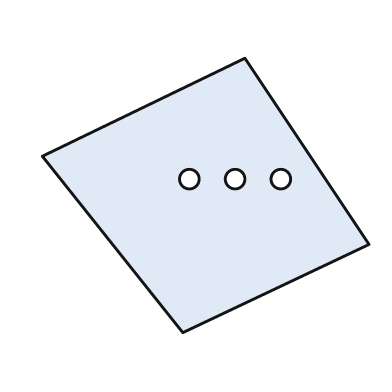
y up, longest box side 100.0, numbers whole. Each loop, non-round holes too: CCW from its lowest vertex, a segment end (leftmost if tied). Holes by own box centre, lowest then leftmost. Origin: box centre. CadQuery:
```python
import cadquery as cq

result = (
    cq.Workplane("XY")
    .moveTo(-7.0, -42.0)
    .lineTo(50.0, -15.0)
    .lineTo(12.0, 42.0)
    .lineTo(-50.0, 12.0)
    .close()
    .moveTo(-5.0, 5.0)
    .circle(3.0)
    .moveTo(9.0, 5.0)
    .circle(3.0)
    .moveTo(23.0, 5.0)
    .circle(3.0)
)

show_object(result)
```